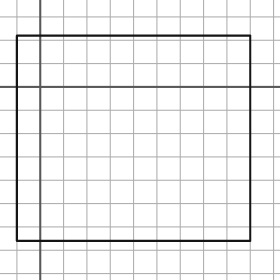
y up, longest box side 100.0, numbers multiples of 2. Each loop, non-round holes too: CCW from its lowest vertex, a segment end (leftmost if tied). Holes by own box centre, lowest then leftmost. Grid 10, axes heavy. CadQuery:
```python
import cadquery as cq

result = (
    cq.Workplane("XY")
    .moveTo(-10.0, -66.0)
    .lineTo(90.0, -66.0)
    .lineTo(90.0, 22.0)
    .lineTo(-10.0, 22.0)
    .close()
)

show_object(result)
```